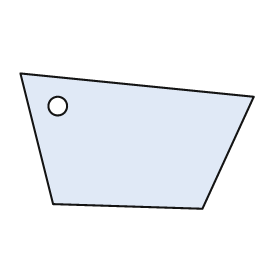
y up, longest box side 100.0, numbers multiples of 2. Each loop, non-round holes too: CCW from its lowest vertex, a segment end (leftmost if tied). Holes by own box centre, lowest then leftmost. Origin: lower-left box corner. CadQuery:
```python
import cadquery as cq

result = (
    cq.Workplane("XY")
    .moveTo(78.0, 0.0)
    .lineTo(100.0, 48.0)
    .lineTo(0.0, 58.0)
    .lineTo(14.0, 2.0)
    .close()
    .moveTo(16.0, 44.0)
    .circle(4.0)
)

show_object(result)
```